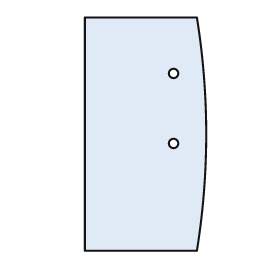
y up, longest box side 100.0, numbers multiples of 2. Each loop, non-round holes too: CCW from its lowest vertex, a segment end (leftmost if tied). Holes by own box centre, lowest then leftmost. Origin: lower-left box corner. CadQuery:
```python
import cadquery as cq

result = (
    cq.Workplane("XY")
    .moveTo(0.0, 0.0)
    .lineTo(48.0, 0.0)
    .threePointArc((52.0, 50.0), (48.0, 100.0))
    .lineTo(0.0, 100.0)
    .close()
    .moveTo(38.0, 46.0)
    .circle(2.0)
    .moveTo(38.0, 76.0)
    .circle(2.0)
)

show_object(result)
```